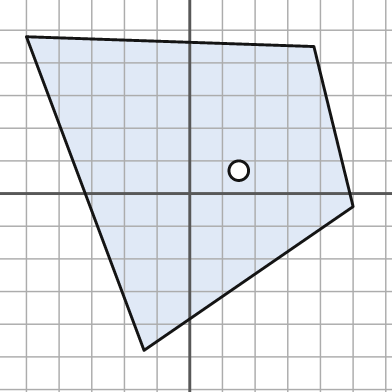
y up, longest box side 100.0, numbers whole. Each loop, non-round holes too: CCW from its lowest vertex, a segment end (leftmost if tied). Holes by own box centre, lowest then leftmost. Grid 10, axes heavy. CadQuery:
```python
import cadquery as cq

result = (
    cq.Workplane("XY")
    .moveTo(-14.0, -48.0)
    .lineTo(50.0, -4.0)
    .lineTo(38.0, 45.0)
    .lineTo(-50.0, 48.0)
    .close()
    .moveTo(15.0, 7.0)
    .circle(3.0)
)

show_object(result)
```